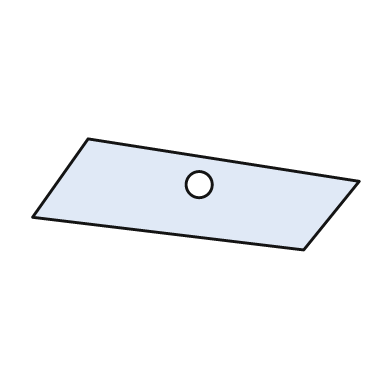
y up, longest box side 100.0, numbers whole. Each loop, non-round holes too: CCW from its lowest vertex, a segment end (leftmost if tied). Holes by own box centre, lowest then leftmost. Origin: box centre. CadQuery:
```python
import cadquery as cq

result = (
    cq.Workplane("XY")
    .moveTo(33.0, -17.0)
    .lineTo(50.0, 4.0)
    .lineTo(-33.0, 17.0)
    .lineTo(-50.0, -7.0)
    .close()
    .moveTo(1.0, 3.0)
    .circle(4.0)
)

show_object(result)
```